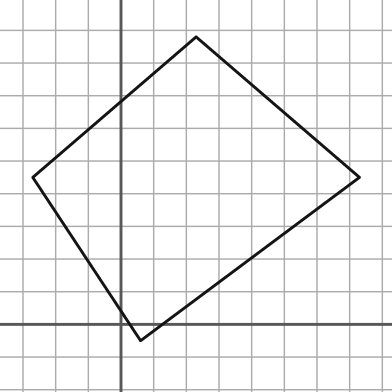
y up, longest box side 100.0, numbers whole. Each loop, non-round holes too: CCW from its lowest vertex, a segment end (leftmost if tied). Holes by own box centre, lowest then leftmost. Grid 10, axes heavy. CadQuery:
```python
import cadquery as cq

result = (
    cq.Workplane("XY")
    .moveTo(6.0, -5.0)
    .lineTo(73.0, 45.0)
    .lineTo(23.0, 88.0)
    .lineTo(-27.0, 45.0)
    .close()
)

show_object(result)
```